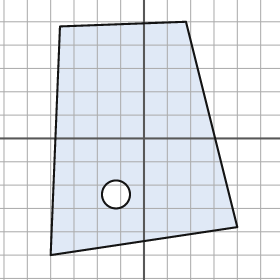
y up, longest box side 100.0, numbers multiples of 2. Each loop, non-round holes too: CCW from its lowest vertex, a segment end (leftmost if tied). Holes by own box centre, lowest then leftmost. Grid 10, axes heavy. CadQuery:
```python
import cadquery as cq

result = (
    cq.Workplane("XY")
    .moveTo(-40.0, -50.0)
    .lineTo(40.0, -38.0)
    .lineTo(18.0, 50.0)
    .lineTo(-36.0, 48.0)
    .close()
    .moveTo(-12.0, -24.0)
    .circle(6.0)
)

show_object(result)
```